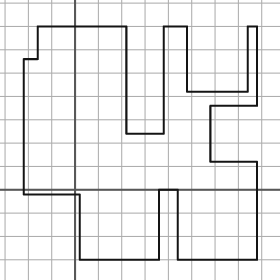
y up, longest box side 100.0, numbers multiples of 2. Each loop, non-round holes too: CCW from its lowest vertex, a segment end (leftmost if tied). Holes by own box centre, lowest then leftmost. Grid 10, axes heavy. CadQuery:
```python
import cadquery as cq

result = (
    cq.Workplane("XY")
    .moveTo(2.0, -30.0)
    .lineTo(36.0, -30.0)
    .lineTo(36.0, 0.0)
    .lineTo(44.0, 0.0)
    .lineTo(44.0, -30.0)
    .lineTo(78.0, -30.0)
    .lineTo(78.0, 12.0)
    .lineTo(58.0, 12.0)
    .lineTo(58.0, 36.0)
    .lineTo(78.0, 36.0)
    .lineTo(78.0, 70.0)
    .lineTo(74.0, 70.0)
    .lineTo(74.0, 42.0)
    .lineTo(48.0, 42.0)
    .lineTo(48.0, 70.0)
    .lineTo(38.0, 70.0)
    .lineTo(38.0, 24.0)
    .lineTo(22.0, 24.0)
    .lineTo(22.0, 70.0)
    .lineTo(-16.0, 70.0)
    .lineTo(-16.0, 56.0)
    .lineTo(-22.0, 56.0)
    .lineTo(-22.0, -2.0)
    .lineTo(2.0, -2.0)
    .close()
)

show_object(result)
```